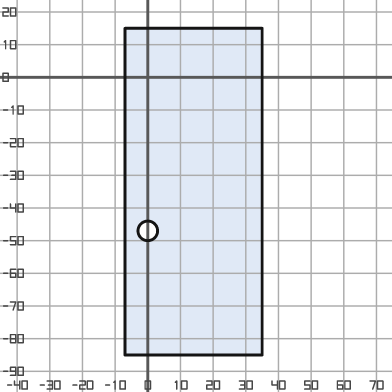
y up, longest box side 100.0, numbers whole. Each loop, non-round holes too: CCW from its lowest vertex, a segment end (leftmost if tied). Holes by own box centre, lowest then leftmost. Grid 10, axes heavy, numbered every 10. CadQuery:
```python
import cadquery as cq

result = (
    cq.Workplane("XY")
    .moveTo(-7.0, -85.0)
    .lineTo(35.0, -85.0)
    .lineTo(35.0, 15.0)
    .lineTo(-7.0, 15.0)
    .close()
    .moveTo(0.0, -47.0)
    .circle(3.0)
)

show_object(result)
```